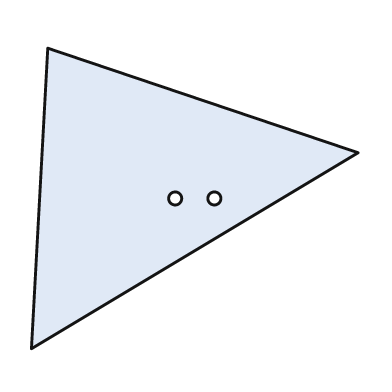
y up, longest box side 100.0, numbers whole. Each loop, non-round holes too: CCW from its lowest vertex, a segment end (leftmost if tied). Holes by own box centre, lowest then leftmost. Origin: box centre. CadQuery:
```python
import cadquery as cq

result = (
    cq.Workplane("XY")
    .moveTo(-50.0, -46.0)
    .lineTo(50.0, 14.0)
    .lineTo(-45.0, 46.0)
    .close()
    .moveTo(-6.0, 0.0)
    .circle(2.0)
    .moveTo(6.0, 0.0)
    .circle(2.0)
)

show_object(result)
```